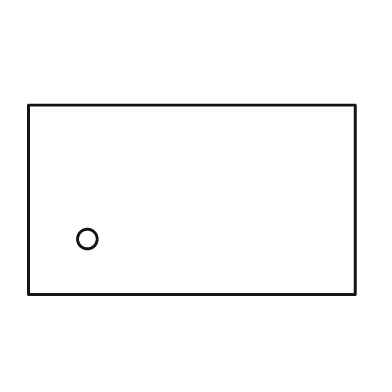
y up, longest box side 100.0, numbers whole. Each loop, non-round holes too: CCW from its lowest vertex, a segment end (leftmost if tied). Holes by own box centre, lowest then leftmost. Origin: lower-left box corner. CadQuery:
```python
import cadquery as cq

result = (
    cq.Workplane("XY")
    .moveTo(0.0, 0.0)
    .lineTo(100.0, 0.0)
    .lineTo(100.0, 58.0)
    .lineTo(0.0, 58.0)
    .close()
    .moveTo(18.0, 17.0)
    .circle(3.0)
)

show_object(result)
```